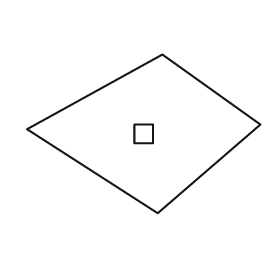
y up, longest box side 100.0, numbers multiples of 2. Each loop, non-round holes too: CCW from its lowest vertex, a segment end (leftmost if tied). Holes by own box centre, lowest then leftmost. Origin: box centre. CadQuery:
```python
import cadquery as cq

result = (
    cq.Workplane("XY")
    .moveTo(6.0, -34.0)
    .lineTo(50.0, 4.0)
    .lineTo(8.0, 34.0)
    .lineTo(-50.0, 2.0)
    .close()
    .moveTo(-4.0, -4.0)
    .lineTo(4.0, -4.0)
    .lineTo(4.0, 4.0)
    .lineTo(-4.0, 4.0)
    .close()
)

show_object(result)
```